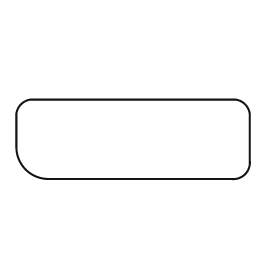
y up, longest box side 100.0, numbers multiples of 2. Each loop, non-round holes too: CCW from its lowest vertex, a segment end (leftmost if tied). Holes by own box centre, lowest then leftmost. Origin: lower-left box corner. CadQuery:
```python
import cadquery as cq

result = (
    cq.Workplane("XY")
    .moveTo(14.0, 0.0)
    .lineTo(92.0, 0.0)
    .threePointArc((98.0, 2.0), (100.0, 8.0))
    .lineTo(100.0, 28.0)
    .threePointArc((98.0, 32.0), (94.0, 34.0))
    .lineTo(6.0, 34.0)
    .threePointArc((2.0, 32.0), (0.0, 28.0))
    .lineTo(0.0, 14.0)
    .threePointArc((4.0, 4.0), (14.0, 0.0))
    .close()
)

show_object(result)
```